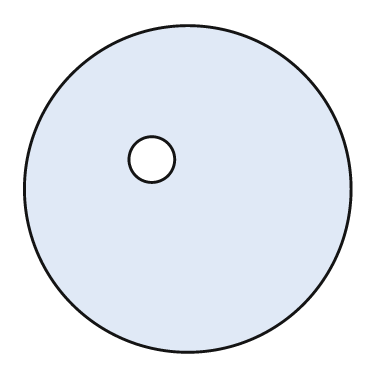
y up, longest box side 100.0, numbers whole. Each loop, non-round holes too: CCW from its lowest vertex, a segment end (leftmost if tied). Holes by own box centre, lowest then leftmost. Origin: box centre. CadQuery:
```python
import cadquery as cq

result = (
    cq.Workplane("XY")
    .moveTo(0.0, 0.0)
    .circle(50.0)
    .moveTo(-11.0, 9.0)
    .circle(7.0)
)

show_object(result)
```